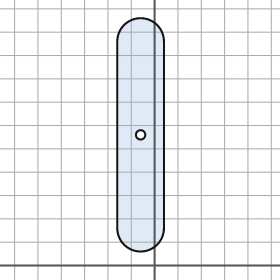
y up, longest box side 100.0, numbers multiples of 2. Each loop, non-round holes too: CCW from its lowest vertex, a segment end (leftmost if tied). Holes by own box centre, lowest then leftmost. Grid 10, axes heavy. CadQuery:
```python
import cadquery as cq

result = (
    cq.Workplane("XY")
    .moveTo(-16.0, 16.0)
    .threePointArc((-6.0, 6.0), (4.0, 16.0))
    .lineTo(4.0, 96.0)
    .threePointArc((-6.0, 106.0), (-16.0, 96.0))
    .close()
    .moveTo(-6.0, 56.0)
    .circle(2.0)
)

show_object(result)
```